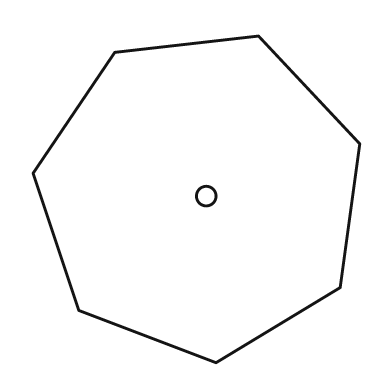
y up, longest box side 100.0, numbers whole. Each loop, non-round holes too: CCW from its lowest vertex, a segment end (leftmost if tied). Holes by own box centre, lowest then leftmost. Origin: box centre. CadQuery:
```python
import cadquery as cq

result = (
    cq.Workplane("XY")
    .moveTo(6.0, -50.0)
    .lineTo(44.0, -27.0)
    .lineTo(50.0, 17.0)
    .lineTo(19.0, 50.0)
    .lineTo(-25.0, 45.0)
    .lineTo(-50.0, 8.0)
    .lineTo(-36.0, -34.0)
    .close()
    .moveTo(3.0, 1.0)
    .circle(3.0)
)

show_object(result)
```